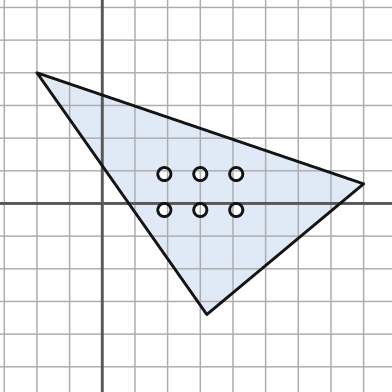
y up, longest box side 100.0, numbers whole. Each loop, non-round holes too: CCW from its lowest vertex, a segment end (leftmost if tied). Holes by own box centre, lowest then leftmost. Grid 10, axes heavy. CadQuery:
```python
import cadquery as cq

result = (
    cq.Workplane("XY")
    .moveTo(32.0, -34.0)
    .lineTo(80.0, 6.0)
    .lineTo(-20.0, 40.0)
    .close()
    .moveTo(19.0, -2.0)
    .circle(2.0)
    .moveTo(30.0, -2.0)
    .circle(2.0)
    .moveTo(41.0, -2.0)
    .circle(2.0)
    .moveTo(19.0, 9.0)
    .circle(2.0)
    .moveTo(30.0, 9.0)
    .circle(2.0)
    .moveTo(41.0, 9.0)
    .circle(2.0)
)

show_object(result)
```